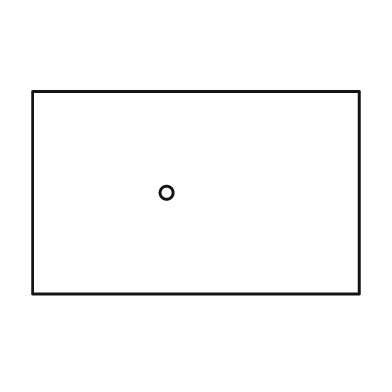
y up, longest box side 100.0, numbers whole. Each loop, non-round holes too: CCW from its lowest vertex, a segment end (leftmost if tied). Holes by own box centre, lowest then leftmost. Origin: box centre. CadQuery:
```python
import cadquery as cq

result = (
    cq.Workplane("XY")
    .moveTo(-50.0, -31.0)
    .lineTo(50.0, -31.0)
    .lineTo(50.0, 31.0)
    .lineTo(-50.0, 31.0)
    .close()
    .moveTo(-9.0, 0.0)
    .circle(2.0)
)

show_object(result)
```